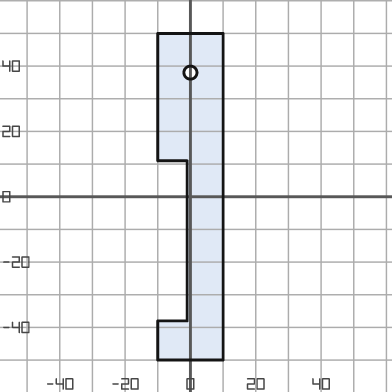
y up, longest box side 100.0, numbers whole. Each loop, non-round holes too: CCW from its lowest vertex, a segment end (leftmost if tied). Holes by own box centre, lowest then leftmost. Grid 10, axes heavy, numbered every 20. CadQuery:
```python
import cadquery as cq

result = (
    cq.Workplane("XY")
    .moveTo(-10.0, -50.0)
    .lineTo(10.0, -50.0)
    .lineTo(10.0, 50.0)
    .lineTo(-10.0, 50.0)
    .lineTo(-10.0, 11.0)
    .lineTo(-1.0, 11.0)
    .lineTo(-1.0, -38.0)
    .lineTo(-10.0, -38.0)
    .close()
    .moveTo(0.0, 38.0)
    .circle(2.0)
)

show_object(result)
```